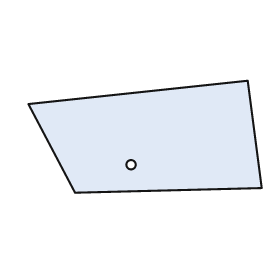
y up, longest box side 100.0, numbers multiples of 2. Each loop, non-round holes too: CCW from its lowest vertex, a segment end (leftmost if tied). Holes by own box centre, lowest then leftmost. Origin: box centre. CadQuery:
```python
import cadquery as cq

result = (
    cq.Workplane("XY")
    .moveTo(-30.0, -24.0)
    .lineTo(50.0, -22.0)
    .lineTo(44.0, 24.0)
    .lineTo(-50.0, 14.0)
    .close()
    .moveTo(-6.0, -12.0)
    .circle(2.0)
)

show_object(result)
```